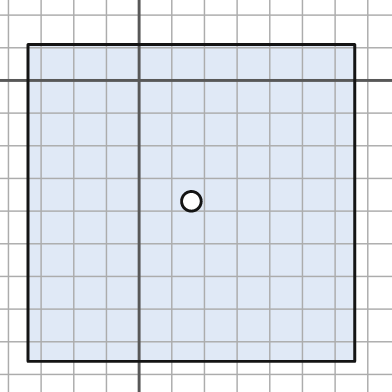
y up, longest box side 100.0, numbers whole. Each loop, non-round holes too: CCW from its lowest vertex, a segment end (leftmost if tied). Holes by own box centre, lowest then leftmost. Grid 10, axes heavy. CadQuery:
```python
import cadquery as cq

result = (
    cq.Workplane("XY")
    .moveTo(-34.0, -86.0)
    .lineTo(66.0, -86.0)
    .lineTo(66.0, 11.0)
    .lineTo(-34.0, 11.0)
    .close()
    .moveTo(16.0, -37.0)
    .circle(3.0)
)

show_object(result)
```